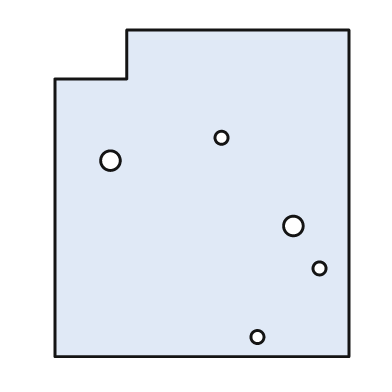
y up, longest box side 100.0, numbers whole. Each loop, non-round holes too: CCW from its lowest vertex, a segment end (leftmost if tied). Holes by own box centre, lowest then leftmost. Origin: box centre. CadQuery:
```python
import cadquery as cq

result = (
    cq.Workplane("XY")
    .moveTo(-45.0, -50.0)
    .lineTo(45.0, -50.0)
    .lineTo(45.0, 50.0)
    .lineTo(-23.0, 50.0)
    .lineTo(-23.0, 35.0)
    .lineTo(-45.0, 35.0)
    .close()
    .moveTo(17.0, -44.0)
    .circle(2.0)
    .moveTo(36.0, -23.0)
    .circle(2.0)
    .moveTo(28.0, -10.0)
    .circle(3.0)
    .moveTo(-28.0, 10.0)
    .circle(3.0)
    .moveTo(6.0, 17.0)
    .circle(2.0)
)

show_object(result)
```